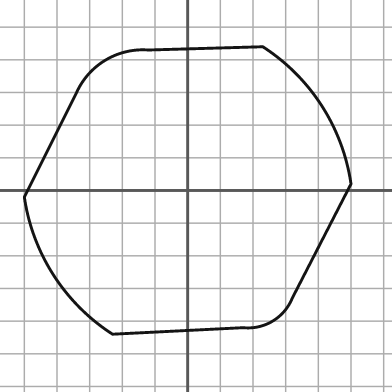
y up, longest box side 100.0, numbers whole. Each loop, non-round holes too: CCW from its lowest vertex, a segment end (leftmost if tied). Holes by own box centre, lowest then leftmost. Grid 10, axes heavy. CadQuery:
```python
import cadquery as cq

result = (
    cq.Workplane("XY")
    .moveTo(-23.0, -44.0)
    .lineTo(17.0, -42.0)
    .threePointArc((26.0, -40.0), (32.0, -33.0))
    .lineTo(50.0, 2.0)
    .threePointArc((41.0, 26.0), (23.0, 44.0))
    .lineTo(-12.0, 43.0)
    .threePointArc((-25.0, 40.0), (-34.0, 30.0))
    .lineTo(-50.0, -2.0)
    .threePointArc((-41.0, -26.0), (-23.0, -44.0))
    .close()
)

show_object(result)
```